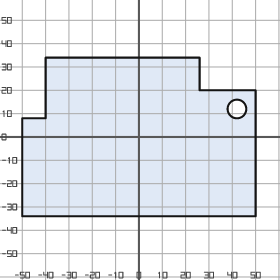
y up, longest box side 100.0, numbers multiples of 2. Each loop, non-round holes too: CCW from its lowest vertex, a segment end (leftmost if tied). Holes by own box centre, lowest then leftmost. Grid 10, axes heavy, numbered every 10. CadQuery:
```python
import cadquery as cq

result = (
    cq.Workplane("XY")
    .moveTo(-50.0, -34.0)
    .lineTo(50.0, -34.0)
    .lineTo(50.0, 20.0)
    .lineTo(26.0, 20.0)
    .lineTo(26.0, 34.0)
    .lineTo(-40.0, 34.0)
    .lineTo(-40.0, 8.0)
    .lineTo(-50.0, 8.0)
    .close()
    .moveTo(42.0, 12.0)
    .circle(4.0)
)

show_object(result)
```